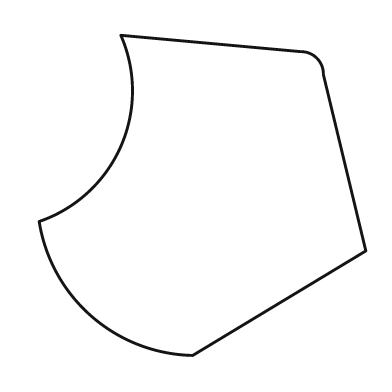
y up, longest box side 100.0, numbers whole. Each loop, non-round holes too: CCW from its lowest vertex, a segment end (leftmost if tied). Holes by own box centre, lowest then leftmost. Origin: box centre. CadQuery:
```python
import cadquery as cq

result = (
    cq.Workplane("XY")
    .moveTo(-3.0, -49.0)
    .lineTo(50.0, -17.0)
    .lineTo(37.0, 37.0)
    .threePointArc((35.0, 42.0), (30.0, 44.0))
    .lineTo(-25.0, 49.0)
    .threePointArc((-25.0, 15.0), (-50.0, -8.0))
    .threePointArc((-34.0, -37.0), (-3.0, -49.0))
    .close()
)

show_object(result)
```